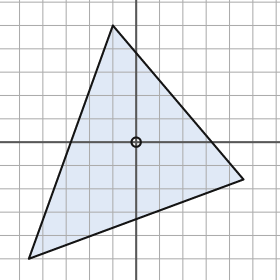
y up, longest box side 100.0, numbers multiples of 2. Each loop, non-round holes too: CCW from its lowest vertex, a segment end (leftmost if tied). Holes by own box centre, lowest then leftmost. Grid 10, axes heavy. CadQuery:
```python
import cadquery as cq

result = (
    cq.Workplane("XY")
    .moveTo(-46.0, -50.0)
    .lineTo(46.0, -16.0)
    .lineTo(-10.0, 50.0)
    .close()
    .moveTo(0.0, 0.0)
    .circle(2.0)
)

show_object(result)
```